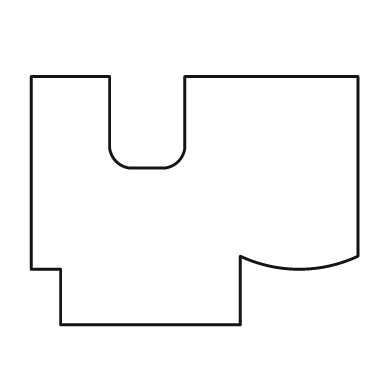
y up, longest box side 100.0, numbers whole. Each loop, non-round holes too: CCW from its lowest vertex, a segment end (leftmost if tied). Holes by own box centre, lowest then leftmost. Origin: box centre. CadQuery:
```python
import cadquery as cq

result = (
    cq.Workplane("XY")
    .moveTo(-41.0, -38.0)
    .lineTo(14.0, -38.0)
    .lineTo(14.0, -17.0)
    .threePointArc((32.0, -21.0), (50.0, -17.0))
    .lineTo(50.0, 38.0)
    .lineTo(-3.0, 38.0)
    .lineTo(-3.0, 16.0)
    .threePointArc((-5.0, 12.0), (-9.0, 10.0))
    .lineTo(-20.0, 10.0)
    .threePointArc((-24.0, 12.0), (-26.0, 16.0))
    .lineTo(-26.0, 38.0)
    .lineTo(-50.0, 38.0)
    .lineTo(-50.0, -21.0)
    .lineTo(-41.0, -21.0)
    .close()
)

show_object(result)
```